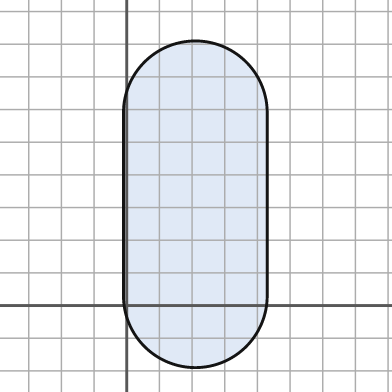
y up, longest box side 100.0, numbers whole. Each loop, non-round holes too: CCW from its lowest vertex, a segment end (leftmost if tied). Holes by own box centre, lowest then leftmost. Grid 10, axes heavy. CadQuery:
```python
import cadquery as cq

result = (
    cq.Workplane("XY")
    .moveTo(-1.0, 3.0)
    .threePointArc((21.0, -19.0), (43.0, 3.0))
    .lineTo(43.0, 59.0)
    .threePointArc((21.0, 81.0), (-1.0, 59.0))
    .close()
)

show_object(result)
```